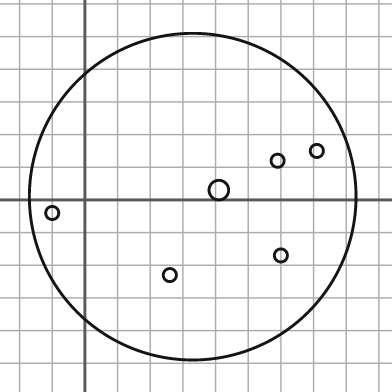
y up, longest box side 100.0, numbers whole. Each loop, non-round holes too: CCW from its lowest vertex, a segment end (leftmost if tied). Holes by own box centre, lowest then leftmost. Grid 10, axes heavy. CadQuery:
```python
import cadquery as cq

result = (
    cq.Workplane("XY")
    .moveTo(33.0, 1.0)
    .circle(50.0)
    .moveTo(26.0, -23.0)
    .circle(2.0)
    .moveTo(60.0, -17.0)
    .circle(2.0)
    .moveTo(-10.0, -4.0)
    .circle(2.0)
    .moveTo(41.0, 3.0)
    .circle(3.0)
    .moveTo(59.0, 12.0)
    .circle(2.0)
    .moveTo(71.0, 15.0)
    .circle(2.0)
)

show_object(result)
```